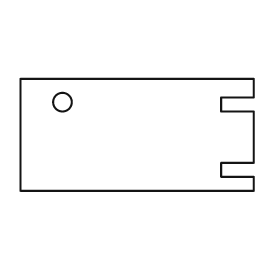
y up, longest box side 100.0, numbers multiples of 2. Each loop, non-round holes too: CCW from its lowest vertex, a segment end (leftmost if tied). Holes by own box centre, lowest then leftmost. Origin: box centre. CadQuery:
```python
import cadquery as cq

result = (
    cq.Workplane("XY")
    .moveTo(-50.0, -24.0)
    .lineTo(50.0, -24.0)
    .lineTo(50.0, -18.0)
    .lineTo(36.0, -18.0)
    .lineTo(36.0, -12.0)
    .lineTo(50.0, -12.0)
    .lineTo(50.0, 10.0)
    .lineTo(36.0, 10.0)
    .lineTo(36.0, 16.0)
    .lineTo(50.0, 16.0)
    .lineTo(50.0, 24.0)
    .lineTo(-50.0, 24.0)
    .close()
    .moveTo(-32.0, 14.0)
    .circle(4.0)
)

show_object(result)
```